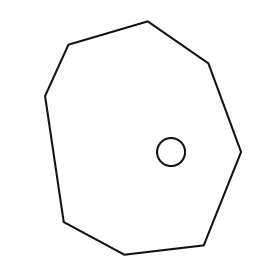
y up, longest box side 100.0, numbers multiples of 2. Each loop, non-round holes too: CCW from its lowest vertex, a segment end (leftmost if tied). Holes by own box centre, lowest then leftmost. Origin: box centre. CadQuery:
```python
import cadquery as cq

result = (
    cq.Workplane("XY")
    .moveTo(-8.0, -50.0)
    .lineTo(26.0, -46.0)
    .lineTo(42.0, -6.0)
    .lineTo(28.0, 32.0)
    .lineTo(2.0, 50.0)
    .lineTo(-32.0, 40.0)
    .lineTo(-42.0, 18.0)
    .lineTo(-34.0, -36.0)
    .close()
    .moveTo(12.0, -6.0)
    .circle(6.0)
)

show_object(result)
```